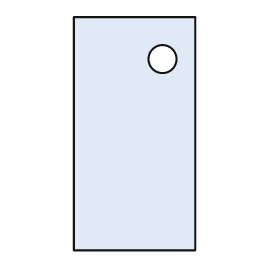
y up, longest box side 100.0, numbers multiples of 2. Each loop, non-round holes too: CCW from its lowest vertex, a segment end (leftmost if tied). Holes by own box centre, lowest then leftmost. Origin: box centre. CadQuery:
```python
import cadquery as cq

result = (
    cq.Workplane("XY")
    .moveTo(-26.0, -50.0)
    .lineTo(26.0, -50.0)
    .lineTo(26.0, 50.0)
    .lineTo(-26.0, 50.0)
    .close()
    .moveTo(12.0, 32.0)
    .circle(6.0)
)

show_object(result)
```